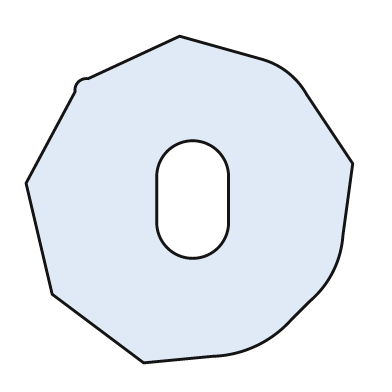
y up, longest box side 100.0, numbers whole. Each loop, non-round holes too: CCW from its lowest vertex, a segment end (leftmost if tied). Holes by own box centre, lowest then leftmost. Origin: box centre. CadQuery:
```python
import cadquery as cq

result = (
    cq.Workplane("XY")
    .moveTo(-14.0, -50.0)
    .lineTo(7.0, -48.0)
    .threePointArc((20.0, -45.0), (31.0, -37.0))
    .lineTo(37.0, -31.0)
    .threePointArc((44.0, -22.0), (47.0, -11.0))
    .lineTo(50.0, 11.0)
    .lineTo(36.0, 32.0)
    .threePointArc((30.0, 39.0), (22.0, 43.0))
    .lineTo(-3.0, 50.0)
    .lineTo(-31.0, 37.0)
    .threePointArc((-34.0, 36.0), (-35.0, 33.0))
    .lineTo(-50.0, 5.0)
    .lineTo(-42.0, -29.0)
    .close()
    .moveTo(-10.0, -7.0)
    .threePointArc((1.0, -18.0), (12.0, -7.0))
    .lineTo(12.0, 7.0)
    .threePointArc((1.0, 18.0), (-10.0, 7.0))
    .close()
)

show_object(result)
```